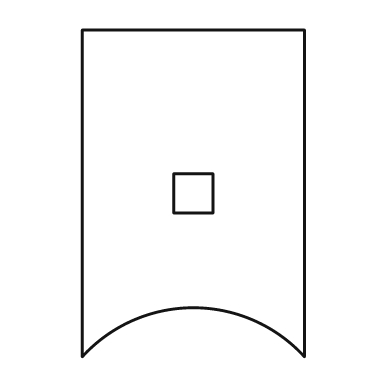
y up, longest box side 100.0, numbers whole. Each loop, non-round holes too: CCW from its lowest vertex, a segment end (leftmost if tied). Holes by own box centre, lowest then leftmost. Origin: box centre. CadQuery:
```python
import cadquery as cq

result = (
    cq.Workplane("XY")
    .moveTo(-34.0, -50.0)
    .threePointArc((0.0, -35.0), (34.0, -50.0))
    .lineTo(34.0, 50.0)
    .lineTo(-34.0, 50.0)
    .close()
    .moveTo(-6.0, -6.0)
    .lineTo(6.0, -6.0)
    .lineTo(6.0, 6.0)
    .lineTo(-6.0, 6.0)
    .close()
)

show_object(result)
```